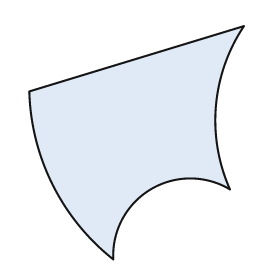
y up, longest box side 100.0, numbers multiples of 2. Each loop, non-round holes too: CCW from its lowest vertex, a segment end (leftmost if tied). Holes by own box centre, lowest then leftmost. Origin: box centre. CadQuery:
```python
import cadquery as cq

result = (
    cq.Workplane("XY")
    .moveTo(-10.0, -50.0)
    .threePointArc((6.0, -20.0), (40.0, -20.0))
    .threePointArc((34.0, 16.0), (46.0, 50.0))
    .lineTo(-46.0, 22.0)
    .threePointArc((-36.0, -18.0), (-10.0, -50.0))
    .close()
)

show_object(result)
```